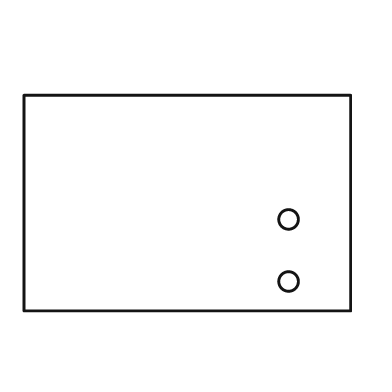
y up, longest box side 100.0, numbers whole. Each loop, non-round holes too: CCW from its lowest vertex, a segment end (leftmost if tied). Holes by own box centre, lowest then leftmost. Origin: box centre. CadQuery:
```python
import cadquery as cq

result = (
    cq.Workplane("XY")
    .moveTo(-50.0, -33.0)
    .lineTo(50.0, -33.0)
    .lineTo(50.0, 33.0)
    .lineTo(-50.0, 33.0)
    .close()
    .moveTo(31.0, -24.0)
    .circle(3.0)
    .moveTo(31.0, -5.0)
    .circle(3.0)
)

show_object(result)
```